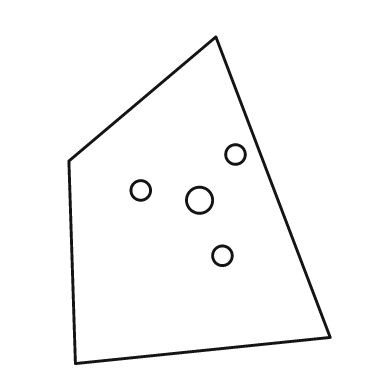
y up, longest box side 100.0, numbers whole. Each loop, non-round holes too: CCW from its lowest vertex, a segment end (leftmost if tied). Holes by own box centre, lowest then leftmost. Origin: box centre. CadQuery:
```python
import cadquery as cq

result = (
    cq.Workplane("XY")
    .moveTo(-38.0, -50.0)
    .lineTo(40.0, -42.0)
    .lineTo(5.0, 50.0)
    .lineTo(-40.0, 12.0)
    .close()
    .moveTo(7.0, -17.0)
    .circle(3.0)
    .moveTo(0.0, 0.0)
    .circle(4.0)
    .moveTo(-18.0, 3.0)
    .circle(3.0)
    .moveTo(11.0, 14.0)
    .circle(3.0)
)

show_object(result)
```